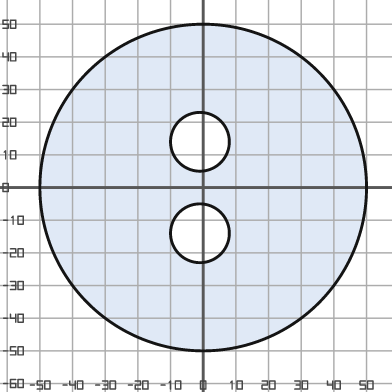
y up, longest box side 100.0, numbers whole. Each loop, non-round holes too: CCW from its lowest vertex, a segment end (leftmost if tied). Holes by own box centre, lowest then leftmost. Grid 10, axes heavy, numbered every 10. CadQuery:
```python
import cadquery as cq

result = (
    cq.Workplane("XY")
    .moveTo(0.0, 0.0)
    .circle(50.0)
    .moveTo(-1.0, -14.0)
    .circle(9.0)
    .moveTo(-1.0, 14.0)
    .circle(9.0)
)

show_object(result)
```